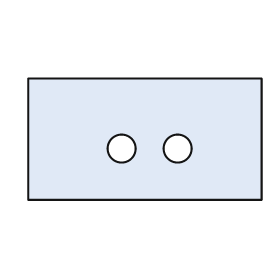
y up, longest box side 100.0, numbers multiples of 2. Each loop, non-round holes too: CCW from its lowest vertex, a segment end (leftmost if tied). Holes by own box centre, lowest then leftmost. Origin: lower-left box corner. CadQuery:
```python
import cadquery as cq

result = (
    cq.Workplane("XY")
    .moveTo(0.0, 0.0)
    .lineTo(100.0, 0.0)
    .lineTo(100.0, 52.0)
    .lineTo(0.0, 52.0)
    .close()
    .moveTo(40.0, 22.0)
    .circle(6.0)
    .moveTo(64.0, 22.0)
    .circle(6.0)
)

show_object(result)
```